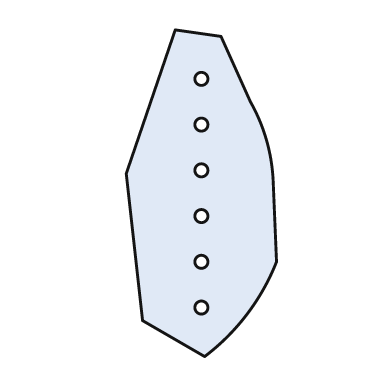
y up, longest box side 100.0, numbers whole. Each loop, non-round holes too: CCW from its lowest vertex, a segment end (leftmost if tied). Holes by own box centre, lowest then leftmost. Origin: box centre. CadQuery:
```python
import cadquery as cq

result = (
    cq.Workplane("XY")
    .moveTo(1.0, -50.0)
    .threePointArc((14.0, -37.0), (23.0, -21.0))
    .lineTo(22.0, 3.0)
    .threePointArc((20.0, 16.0), (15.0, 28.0))
    .lineTo(6.0, 48.0)
    .lineTo(-8.0, 50.0)
    .lineTo(-23.0, 6.0)
    .lineTo(-18.0, -39.0)
    .close()
    .moveTo(0.0, -35.0)
    .circle(2.0)
    .moveTo(0.0, -21.0)
    .circle(2.0)
    .moveTo(0.0, -7.0)
    .circle(2.0)
    .moveTo(0.0, 7.0)
    .circle(2.0)
    .moveTo(0.0, 21.0)
    .circle(2.0)
    .moveTo(0.0, 35.0)
    .circle(2.0)
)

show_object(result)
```